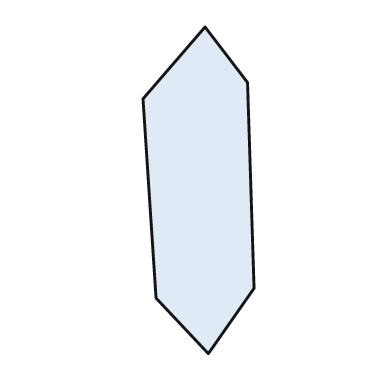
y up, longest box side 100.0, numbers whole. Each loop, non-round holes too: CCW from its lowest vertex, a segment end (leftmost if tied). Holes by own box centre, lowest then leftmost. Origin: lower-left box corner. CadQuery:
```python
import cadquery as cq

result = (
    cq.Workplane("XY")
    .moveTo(20.0, 0.0)
    .lineTo(34.0, 20.0)
    .lineTo(32.0, 83.0)
    .lineTo(19.0, 100.0)
    .lineTo(0.0, 78.0)
    .lineTo(4.0, 17.0)
    .close()
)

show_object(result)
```